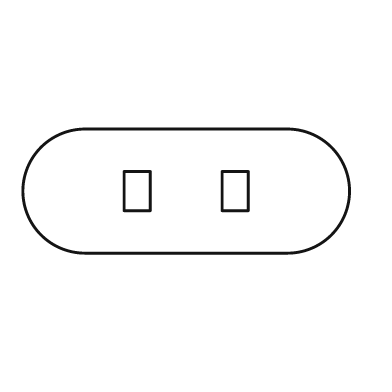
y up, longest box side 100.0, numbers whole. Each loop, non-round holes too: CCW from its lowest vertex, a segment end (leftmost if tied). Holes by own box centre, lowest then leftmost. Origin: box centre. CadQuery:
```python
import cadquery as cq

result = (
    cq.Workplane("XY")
    .moveTo(-31.0, -19.0)
    .lineTo(31.0, -19.0)
    .threePointArc((50.0, 0.0), (31.0, 19.0))
    .lineTo(-31.0, 19.0)
    .threePointArc((-50.0, 0.0), (-31.0, -19.0))
    .close()
    .moveTo(-19.0, -6.0)
    .lineTo(-11.0, -6.0)
    .lineTo(-11.0, 6.0)
    .lineTo(-19.0, 6.0)
    .close()
    .moveTo(11.0, -6.0)
    .lineTo(19.0, -6.0)
    .lineTo(19.0, 6.0)
    .lineTo(11.0, 6.0)
    .close()
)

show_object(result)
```